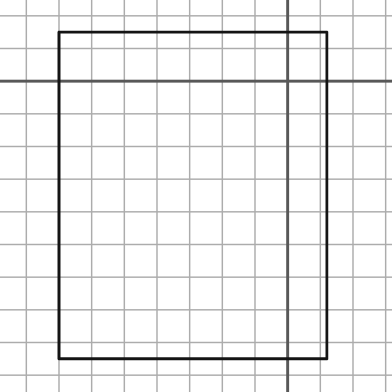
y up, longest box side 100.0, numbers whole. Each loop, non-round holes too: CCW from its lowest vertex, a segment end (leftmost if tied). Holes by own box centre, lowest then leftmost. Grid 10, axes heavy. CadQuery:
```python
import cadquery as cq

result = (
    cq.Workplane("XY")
    .moveTo(-70.0, -85.0)
    .lineTo(12.0, -85.0)
    .lineTo(12.0, 15.0)
    .lineTo(-70.0, 15.0)
    .close()
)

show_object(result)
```